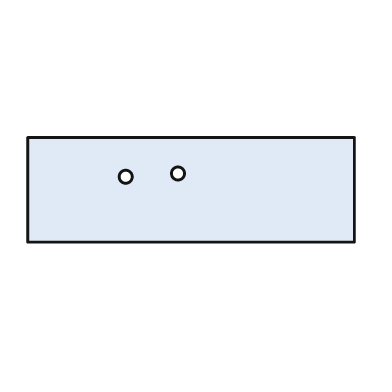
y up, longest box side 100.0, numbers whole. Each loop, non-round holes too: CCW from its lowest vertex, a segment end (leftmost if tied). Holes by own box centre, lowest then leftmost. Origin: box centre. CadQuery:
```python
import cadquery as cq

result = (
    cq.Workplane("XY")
    .moveTo(-50.0, -16.0)
    .lineTo(50.0, -16.0)
    .lineTo(50.0, 16.0)
    .lineTo(-50.0, 16.0)
    .close()
    .moveTo(-20.0, 4.0)
    .circle(2.0)
    .moveTo(-4.0, 5.0)
    .circle(2.0)
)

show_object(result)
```